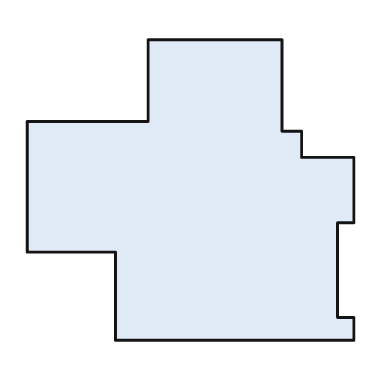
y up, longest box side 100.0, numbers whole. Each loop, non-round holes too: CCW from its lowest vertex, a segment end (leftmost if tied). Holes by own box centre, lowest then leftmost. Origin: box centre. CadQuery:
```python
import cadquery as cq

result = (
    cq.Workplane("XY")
    .moveTo(-23.0, -46.0)
    .lineTo(50.0, -46.0)
    .lineTo(50.0, -39.0)
    .lineTo(45.0, -39.0)
    .lineTo(45.0, -10.0)
    .lineTo(50.0, -10.0)
    .lineTo(50.0, 10.0)
    .lineTo(34.0, 10.0)
    .lineTo(34.0, 18.0)
    .lineTo(28.0, 18.0)
    .lineTo(28.0, 46.0)
    .lineTo(-13.0, 46.0)
    .lineTo(-13.0, 21.0)
    .lineTo(-50.0, 21.0)
    .lineTo(-50.0, -19.0)
    .lineTo(-23.0, -19.0)
    .close()
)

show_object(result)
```